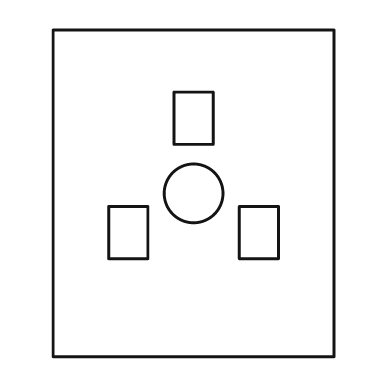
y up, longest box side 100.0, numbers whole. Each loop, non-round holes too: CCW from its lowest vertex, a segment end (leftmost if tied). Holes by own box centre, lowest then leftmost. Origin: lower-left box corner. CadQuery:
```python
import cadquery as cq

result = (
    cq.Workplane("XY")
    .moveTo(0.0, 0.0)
    .lineTo(86.0, 0.0)
    .lineTo(86.0, 100.0)
    .lineTo(0.0, 100.0)
    .close()
    .moveTo(17.0, 30.0)
    .lineTo(29.0, 30.0)
    .lineTo(29.0, 46.0)
    .lineTo(17.0, 46.0)
    .close()
    .moveTo(57.0, 30.0)
    .lineTo(69.0, 30.0)
    .lineTo(69.0, 46.0)
    .lineTo(57.0, 46.0)
    .close()
    .moveTo(43.0, 50.0)
    .circle(9.0)
    .moveTo(37.0, 65.0)
    .lineTo(49.0, 65.0)
    .lineTo(49.0, 81.0)
    .lineTo(37.0, 81.0)
    .close()
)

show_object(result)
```